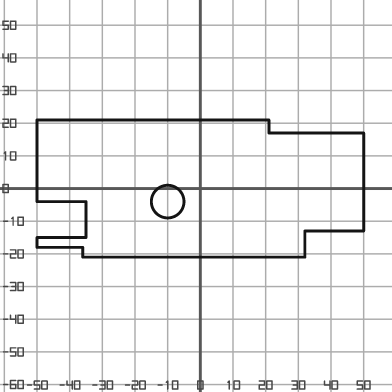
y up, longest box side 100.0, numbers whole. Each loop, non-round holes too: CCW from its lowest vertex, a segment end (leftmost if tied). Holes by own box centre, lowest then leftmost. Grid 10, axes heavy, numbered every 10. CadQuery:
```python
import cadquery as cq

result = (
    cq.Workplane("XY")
    .moveTo(-36.0, -21.0)
    .lineTo(32.0, -21.0)
    .lineTo(32.0, -13.0)
    .lineTo(50.0, -13.0)
    .lineTo(50.0, 17.0)
    .lineTo(21.0, 17.0)
    .lineTo(21.0, 21.0)
    .lineTo(-50.0, 21.0)
    .lineTo(-50.0, -4.0)
    .lineTo(-35.0, -4.0)
    .lineTo(-35.0, -15.0)
    .lineTo(-50.0, -15.0)
    .lineTo(-50.0, -18.0)
    .lineTo(-36.0, -18.0)
    .close()
    .moveTo(-10.0, -4.0)
    .circle(5.0)
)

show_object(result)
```